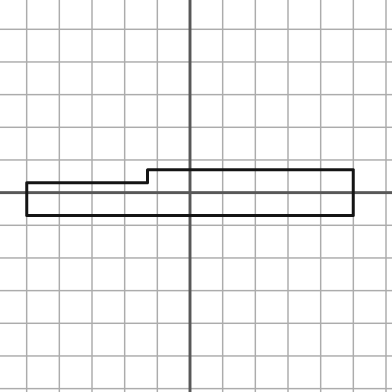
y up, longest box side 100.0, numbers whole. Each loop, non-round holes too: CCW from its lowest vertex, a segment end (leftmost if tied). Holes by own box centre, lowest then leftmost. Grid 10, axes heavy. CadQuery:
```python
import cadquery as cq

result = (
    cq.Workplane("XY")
    .moveTo(-50.0, -7.0)
    .lineTo(50.0, -7.0)
    .lineTo(50.0, 7.0)
    .lineTo(-13.0, 7.0)
    .lineTo(-13.0, 3.0)
    .lineTo(-50.0, 3.0)
    .close()
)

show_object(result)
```